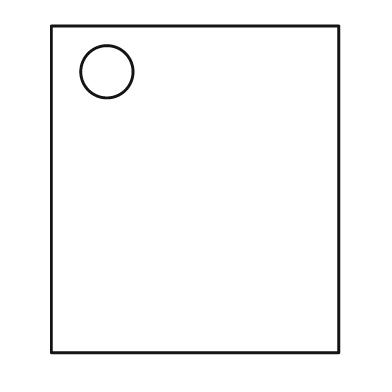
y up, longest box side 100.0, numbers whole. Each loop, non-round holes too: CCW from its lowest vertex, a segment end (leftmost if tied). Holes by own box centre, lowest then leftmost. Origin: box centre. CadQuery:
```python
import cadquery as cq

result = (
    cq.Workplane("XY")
    .moveTo(-44.0, -50.0)
    .lineTo(44.0, -50.0)
    .lineTo(44.0, 50.0)
    .lineTo(-44.0, 50.0)
    .close()
    .moveTo(-27.0, 36.0)
    .circle(8.0)
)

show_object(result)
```